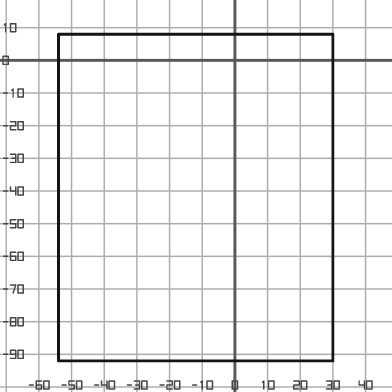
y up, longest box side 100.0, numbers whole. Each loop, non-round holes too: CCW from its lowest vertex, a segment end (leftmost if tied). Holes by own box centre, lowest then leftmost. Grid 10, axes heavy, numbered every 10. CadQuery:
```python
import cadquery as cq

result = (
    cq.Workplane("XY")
    .moveTo(-54.0, -92.0)
    .lineTo(30.0, -92.0)
    .lineTo(30.0, 8.0)
    .lineTo(-54.0, 8.0)
    .close()
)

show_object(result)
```